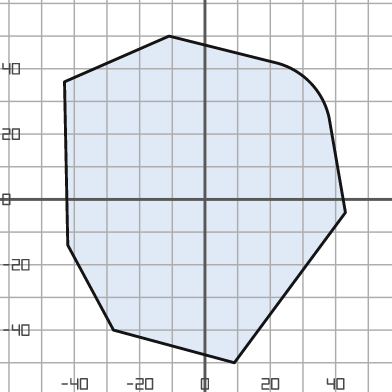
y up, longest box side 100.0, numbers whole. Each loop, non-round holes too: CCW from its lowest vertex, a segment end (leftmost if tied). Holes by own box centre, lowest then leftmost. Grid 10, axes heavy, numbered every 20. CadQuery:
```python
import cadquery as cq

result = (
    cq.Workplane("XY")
    .moveTo(9.0, -50.0)
    .lineTo(43.0, -4.0)
    .lineTo(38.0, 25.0)
    .threePointArc((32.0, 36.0), (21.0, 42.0))
    .lineTo(-11.0, 50.0)
    .lineTo(-43.0, 36.0)
    .lineTo(-42.0, -14.0)
    .lineTo(-28.0, -40.0)
    .close()
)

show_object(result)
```